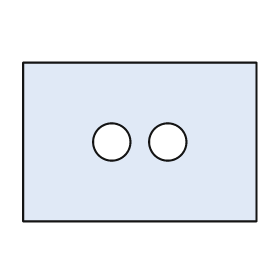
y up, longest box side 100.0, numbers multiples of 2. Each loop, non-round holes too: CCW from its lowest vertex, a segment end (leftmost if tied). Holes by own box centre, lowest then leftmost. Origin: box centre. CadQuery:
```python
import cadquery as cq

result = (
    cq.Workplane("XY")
    .moveTo(-50.0, -34.0)
    .lineTo(50.0, -34.0)
    .lineTo(50.0, 34.0)
    .lineTo(-50.0, 34.0)
    .close()
    .moveTo(-12.0, 0.0)
    .circle(8.0)
    .moveTo(12.0, 0.0)
    .circle(8.0)
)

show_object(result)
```